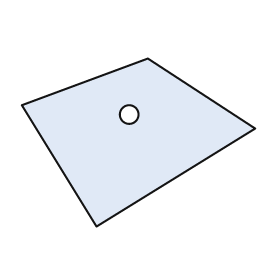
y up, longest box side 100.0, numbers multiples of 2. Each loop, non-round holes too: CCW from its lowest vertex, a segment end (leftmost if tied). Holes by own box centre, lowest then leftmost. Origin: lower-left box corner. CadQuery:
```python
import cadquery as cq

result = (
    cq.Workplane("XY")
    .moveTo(32.0, 0.0)
    .lineTo(100.0, 42.0)
    .lineTo(54.0, 72.0)
    .lineTo(0.0, 52.0)
    .close()
    .moveTo(46.0, 48.0)
    .circle(4.0)
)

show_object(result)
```